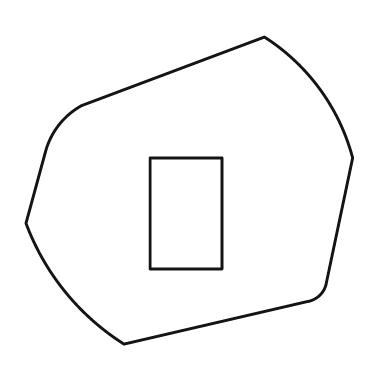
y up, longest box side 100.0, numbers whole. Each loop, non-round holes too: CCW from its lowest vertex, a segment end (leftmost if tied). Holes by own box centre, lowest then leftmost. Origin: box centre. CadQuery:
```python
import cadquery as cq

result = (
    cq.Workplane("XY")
    .moveTo(-20.0, -47.0)
    .lineTo(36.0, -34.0)
    .threePointArc((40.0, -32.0), (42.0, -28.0))
    .lineTo(50.0, 10.0)
    .threePointArc((40.0, 31.0), (23.0, 47.0))
    .lineTo(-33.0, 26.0)
    .threePointArc((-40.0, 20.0), (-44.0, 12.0))
    .lineTo(-50.0, -10.0)
    .threePointArc((-38.0, -31.0), (-20.0, -47.0))
    .close()
    .moveTo(-12.0, -24.0)
    .lineTo(10.0, -24.0)
    .lineTo(10.0, 10.0)
    .lineTo(-12.0, 10.0)
    .close()
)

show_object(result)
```